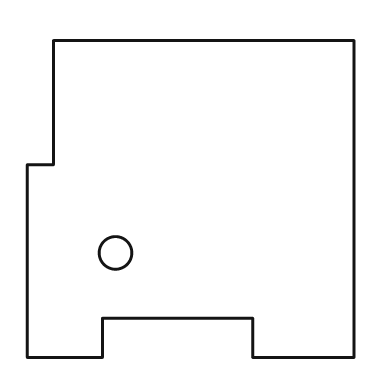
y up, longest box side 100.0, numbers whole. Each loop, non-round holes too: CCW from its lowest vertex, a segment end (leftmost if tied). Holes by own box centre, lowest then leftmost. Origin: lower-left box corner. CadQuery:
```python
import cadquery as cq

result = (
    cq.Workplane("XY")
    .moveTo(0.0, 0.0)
    .lineTo(23.0, 0.0)
    .lineTo(23.0, 12.0)
    .lineTo(69.0, 12.0)
    .lineTo(69.0, 0.0)
    .lineTo(100.0, 0.0)
    .lineTo(100.0, 97.0)
    .lineTo(8.0, 97.0)
    .lineTo(8.0, 59.0)
    .lineTo(0.0, 59.0)
    .close()
    .moveTo(27.0, 32.0)
    .circle(5.0)
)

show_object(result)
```